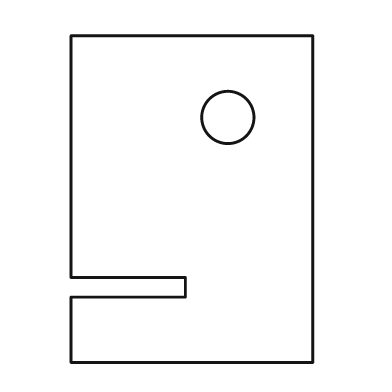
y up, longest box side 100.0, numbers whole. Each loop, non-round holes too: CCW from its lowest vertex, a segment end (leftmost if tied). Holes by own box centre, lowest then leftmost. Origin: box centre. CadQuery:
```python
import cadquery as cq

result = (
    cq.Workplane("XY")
    .moveTo(-37.0, -50.0)
    .lineTo(37.0, -50.0)
    .lineTo(37.0, 50.0)
    .lineTo(-37.0, 50.0)
    .lineTo(-37.0, -24.0)
    .lineTo(-2.0, -24.0)
    .lineTo(-2.0, -30.0)
    .lineTo(-37.0, -30.0)
    .close()
    .moveTo(11.0, 25.0)
    .circle(8.0)
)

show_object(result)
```